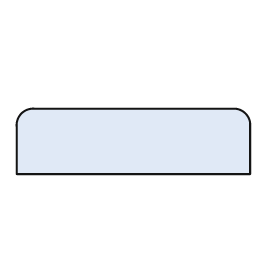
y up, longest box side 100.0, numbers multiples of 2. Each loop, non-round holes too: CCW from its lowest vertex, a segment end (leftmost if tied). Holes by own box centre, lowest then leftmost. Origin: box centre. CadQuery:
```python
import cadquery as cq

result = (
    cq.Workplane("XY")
    .moveTo(-50.0, -14.0)
    .lineTo(50.0, -14.0)
    .lineTo(50.0, 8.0)
    .threePointArc((48.0, 12.0), (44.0, 14.0))
    .lineTo(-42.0, 14.0)
    .threePointArc((-48.0, 12.0), (-50.0, 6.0))
    .close()
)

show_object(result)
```